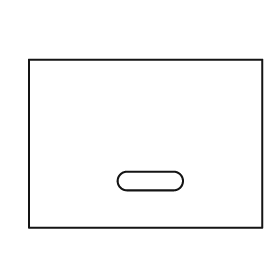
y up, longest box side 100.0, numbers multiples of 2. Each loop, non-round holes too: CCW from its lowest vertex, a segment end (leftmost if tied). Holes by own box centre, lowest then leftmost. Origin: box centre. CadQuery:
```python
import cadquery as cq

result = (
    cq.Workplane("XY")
    .moveTo(-50.0, -36.0)
    .lineTo(50.0, -36.0)
    .lineTo(50.0, 36.0)
    .lineTo(-50.0, 36.0)
    .close()
    .moveTo(-8.0, -20.0)
    .lineTo(12.0, -20.0)
    .threePointArc((16.0, -16.0), (12.0, -12.0))
    .lineTo(-8.0, -12.0)
    .threePointArc((-12.0, -16.0), (-8.0, -20.0))
    .close()
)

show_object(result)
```